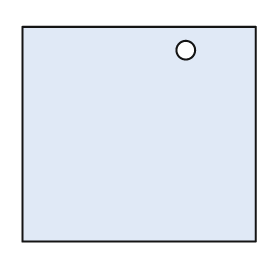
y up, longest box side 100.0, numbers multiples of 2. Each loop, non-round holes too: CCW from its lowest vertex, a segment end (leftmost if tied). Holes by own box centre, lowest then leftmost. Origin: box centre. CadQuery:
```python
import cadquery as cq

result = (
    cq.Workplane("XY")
    .moveTo(-50.0, -46.0)
    .lineTo(50.0, -46.0)
    .lineTo(50.0, 46.0)
    .lineTo(-50.0, 46.0)
    .close()
    .moveTo(20.0, 36.0)
    .circle(4.0)
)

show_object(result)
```